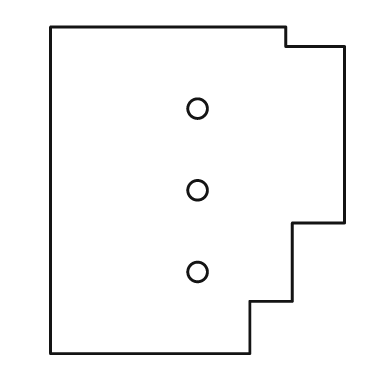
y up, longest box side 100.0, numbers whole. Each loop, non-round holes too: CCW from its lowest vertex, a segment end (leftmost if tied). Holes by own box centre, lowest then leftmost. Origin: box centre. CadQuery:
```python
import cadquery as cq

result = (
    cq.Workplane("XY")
    .moveTo(-45.0, -50.0)
    .lineTo(16.0, -50.0)
    .lineTo(16.0, -34.0)
    .lineTo(29.0, -34.0)
    .lineTo(29.0, -10.0)
    .lineTo(45.0, -10.0)
    .lineTo(45.0, 44.0)
    .lineTo(27.0, 44.0)
    .lineTo(27.0, 50.0)
    .lineTo(-45.0, 50.0)
    .close()
    .moveTo(0.0, -25.0)
    .circle(3.0)
    .moveTo(0.0, 0.0)
    .circle(3.0)
    .moveTo(0.0, 25.0)
    .circle(3.0)
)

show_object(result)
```